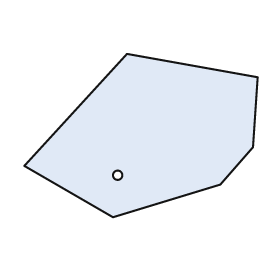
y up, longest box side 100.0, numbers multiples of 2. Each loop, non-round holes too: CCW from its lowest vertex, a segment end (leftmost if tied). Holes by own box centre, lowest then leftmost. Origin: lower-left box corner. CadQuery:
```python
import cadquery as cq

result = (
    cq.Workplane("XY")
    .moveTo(38.0, 0.0)
    .lineTo(84.0, 14.0)
    .lineTo(98.0, 30.0)
    .lineTo(100.0, 60.0)
    .lineTo(44.0, 70.0)
    .lineTo(0.0, 22.0)
    .close()
    .moveTo(40.0, 18.0)
    .circle(2.0)
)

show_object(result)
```